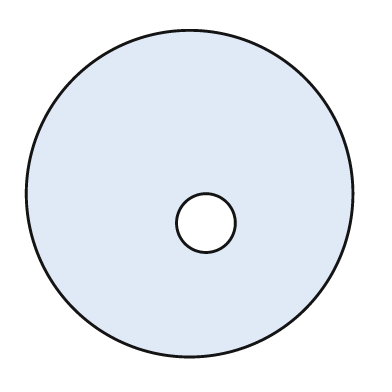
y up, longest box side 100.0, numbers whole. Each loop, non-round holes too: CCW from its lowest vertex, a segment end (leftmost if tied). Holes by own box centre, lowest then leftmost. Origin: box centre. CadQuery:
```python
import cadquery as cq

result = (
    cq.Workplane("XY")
    .moveTo(0.0, 0.0)
    .circle(50.0)
    .moveTo(5.0, -9.0)
    .circle(9.0)
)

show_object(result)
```